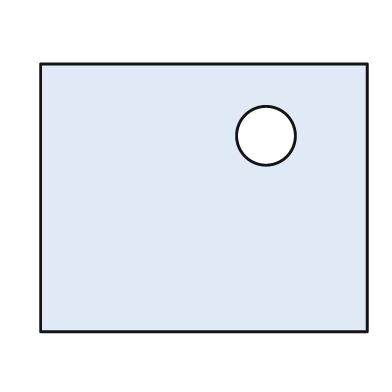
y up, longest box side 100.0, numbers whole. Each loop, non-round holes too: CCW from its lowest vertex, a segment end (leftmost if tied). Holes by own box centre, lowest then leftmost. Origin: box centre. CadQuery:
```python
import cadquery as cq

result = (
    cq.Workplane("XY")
    .moveTo(-50.0, -41.0)
    .lineTo(50.0, -41.0)
    .lineTo(50.0, 41.0)
    .lineTo(-50.0, 41.0)
    .close()
    .moveTo(19.0, 19.0)
    .circle(9.0)
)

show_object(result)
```